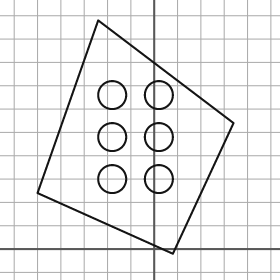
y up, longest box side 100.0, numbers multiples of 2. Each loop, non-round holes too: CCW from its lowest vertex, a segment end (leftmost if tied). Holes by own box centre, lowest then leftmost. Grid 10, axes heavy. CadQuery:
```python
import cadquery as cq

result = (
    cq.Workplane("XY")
    .moveTo(8.0, -2.0)
    .lineTo(34.0, 54.0)
    .lineTo(-24.0, 98.0)
    .lineTo(-50.0, 24.0)
    .close()
    .moveTo(-18.0, 30.0)
    .circle(6.0)
    .moveTo(2.0, 30.0)
    .circle(6.0)
    .moveTo(-18.0, 48.0)
    .circle(6.0)
    .moveTo(2.0, 48.0)
    .circle(6.0)
    .moveTo(-18.0, 66.0)
    .circle(6.0)
    .moveTo(2.0, 66.0)
    .circle(6.0)
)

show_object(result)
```